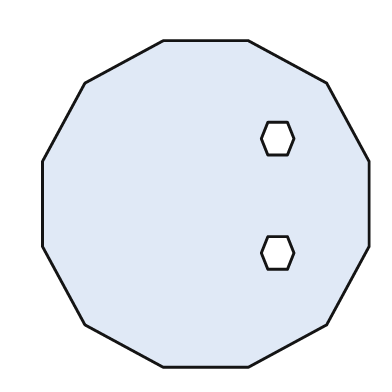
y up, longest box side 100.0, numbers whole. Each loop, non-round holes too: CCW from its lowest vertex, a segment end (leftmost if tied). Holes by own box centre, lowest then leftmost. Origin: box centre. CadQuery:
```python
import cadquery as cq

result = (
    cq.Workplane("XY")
    .moveTo(-13.0, -50.0)
    .lineTo(13.0, -50.0)
    .lineTo(37.0, -37.0)
    .lineTo(50.0, -13.0)
    .lineTo(50.0, 13.0)
    .lineTo(37.0, 37.0)
    .lineTo(13.0, 50.0)
    .lineTo(-13.0, 50.0)
    .lineTo(-37.0, 37.0)
    .lineTo(-50.0, 13.0)
    .lineTo(-50.0, -13.0)
    .lineTo(-37.0, -37.0)
    .close()
    .moveTo(19.0, -20.0)
    .lineTo(25.0, -20.0)
    .lineTo(27.0, -15.0)
    .lineTo(25.0, -10.0)
    .lineTo(19.0, -10.0)
    .lineTo(17.0, -15.0)
    .close()
    .moveTo(19.0, 15.0)
    .lineTo(25.0, 15.0)
    .lineTo(27.0, 20.0)
    .lineTo(25.0, 25.0)
    .lineTo(19.0, 25.0)
    .lineTo(17.0, 20.0)
    .close()
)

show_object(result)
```